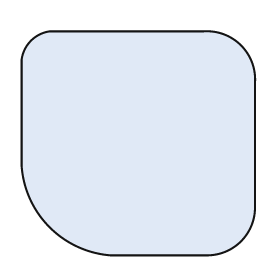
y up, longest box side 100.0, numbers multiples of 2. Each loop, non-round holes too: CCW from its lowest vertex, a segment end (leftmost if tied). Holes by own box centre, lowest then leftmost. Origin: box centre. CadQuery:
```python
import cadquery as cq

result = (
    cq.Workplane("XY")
    .moveTo(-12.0, -48.0)
    .lineTo(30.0, -48.0)
    .threePointArc((44.0, -42.0), (50.0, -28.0))
    .lineTo(50.0, 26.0)
    .threePointArc((44.0, 42.0), (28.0, 48.0))
    .lineTo(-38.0, 48.0)
    .threePointArc((-46.0, 44.0), (-50.0, 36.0))
    .lineTo(-50.0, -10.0)
    .threePointArc((-38.0, -36.0), (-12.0, -48.0))
    .close()
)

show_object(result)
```